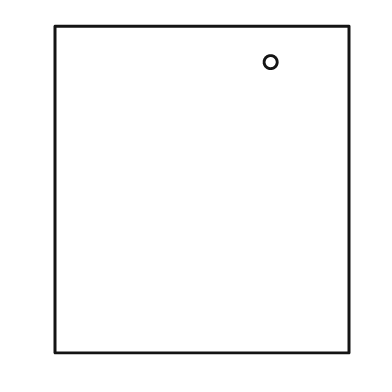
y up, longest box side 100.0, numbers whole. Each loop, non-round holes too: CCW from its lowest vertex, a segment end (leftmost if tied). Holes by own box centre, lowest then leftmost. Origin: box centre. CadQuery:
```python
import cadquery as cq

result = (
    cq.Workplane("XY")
    .moveTo(-45.0, -50.0)
    .lineTo(45.0, -50.0)
    .lineTo(45.0, 50.0)
    .lineTo(-45.0, 50.0)
    .close()
    .moveTo(21.0, 39.0)
    .circle(2.0)
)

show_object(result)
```